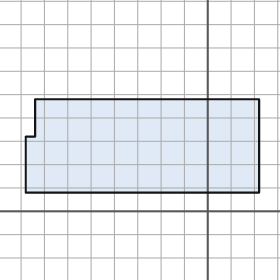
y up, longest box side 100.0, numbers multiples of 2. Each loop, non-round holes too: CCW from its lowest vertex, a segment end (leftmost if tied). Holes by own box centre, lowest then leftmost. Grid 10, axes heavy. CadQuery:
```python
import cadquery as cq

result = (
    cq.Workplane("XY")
    .moveTo(-78.0, 8.0)
    .lineTo(22.0, 8.0)
    .lineTo(22.0, 48.0)
    .lineTo(-74.0, 48.0)
    .lineTo(-74.0, 32.0)
    .lineTo(-78.0, 32.0)
    .close()
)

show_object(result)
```